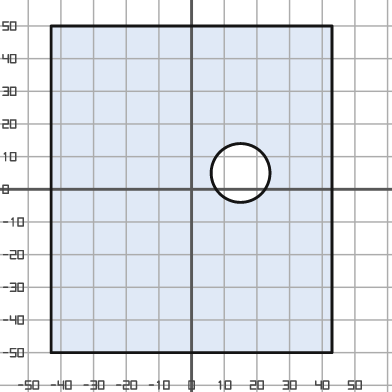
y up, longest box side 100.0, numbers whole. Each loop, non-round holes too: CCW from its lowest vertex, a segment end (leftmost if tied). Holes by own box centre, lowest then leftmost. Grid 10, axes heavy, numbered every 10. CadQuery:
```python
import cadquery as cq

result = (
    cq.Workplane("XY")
    .moveTo(-43.0, -50.0)
    .lineTo(43.0, -50.0)
    .lineTo(43.0, 50.0)
    .lineTo(-43.0, 50.0)
    .close()
    .moveTo(15.0, 5.0)
    .circle(9.0)
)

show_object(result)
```